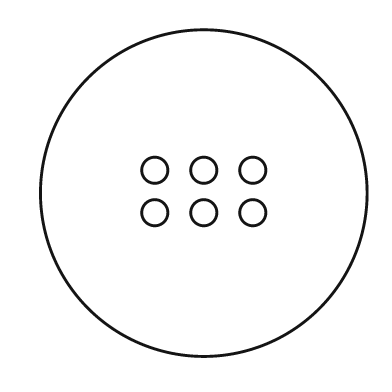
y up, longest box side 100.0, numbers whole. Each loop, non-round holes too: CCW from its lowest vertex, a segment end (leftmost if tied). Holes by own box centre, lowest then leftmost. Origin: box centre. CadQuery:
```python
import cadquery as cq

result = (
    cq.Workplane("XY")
    .moveTo(0.0, 0.0)
    .circle(50.0)
    .moveTo(-15.0, -6.0)
    .circle(4.0)
    .moveTo(0.0, -6.0)
    .circle(4.0)
    .moveTo(15.0, -6.0)
    .circle(4.0)
    .moveTo(-15.0, 7.0)
    .circle(4.0)
    .moveTo(0.0, 7.0)
    .circle(4.0)
    .moveTo(15.0, 7.0)
    .circle(4.0)
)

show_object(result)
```